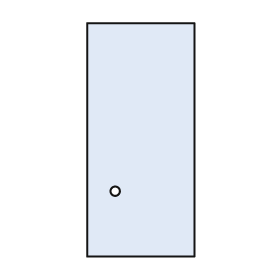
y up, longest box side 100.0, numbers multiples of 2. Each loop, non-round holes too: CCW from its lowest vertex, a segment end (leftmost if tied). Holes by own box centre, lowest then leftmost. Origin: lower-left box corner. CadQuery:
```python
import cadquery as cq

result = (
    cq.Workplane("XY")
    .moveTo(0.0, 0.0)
    .lineTo(46.0, 0.0)
    .lineTo(46.0, 100.0)
    .lineTo(0.0, 100.0)
    .close()
    .moveTo(12.0, 28.0)
    .circle(2.0)
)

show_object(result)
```